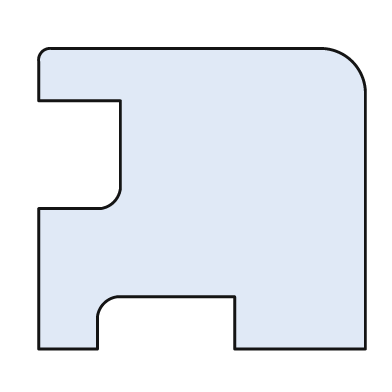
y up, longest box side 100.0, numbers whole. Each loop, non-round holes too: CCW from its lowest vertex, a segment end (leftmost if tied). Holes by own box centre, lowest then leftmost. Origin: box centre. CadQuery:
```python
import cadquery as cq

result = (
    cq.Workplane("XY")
    .moveTo(-50.0, -46.0)
    .lineTo(-32.0, -46.0)
    .lineTo(-32.0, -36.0)
    .threePointArc((-30.0, -32.0), (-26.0, -30.0))
    .lineTo(10.0, -30.0)
    .lineTo(10.0, -46.0)
    .lineTo(50.0, -46.0)
    .lineTo(50.0, 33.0)
    .threePointArc((46.0, 42.0), (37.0, 46.0))
    .lineTo(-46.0, 46.0)
    .threePointArc((-49.0, 45.0), (-50.0, 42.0))
    .lineTo(-50.0, 30.0)
    .lineTo(-25.0, 30.0)
    .lineTo(-25.0, 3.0)
    .threePointArc((-27.0, -1.0), (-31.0, -3.0))
    .lineTo(-50.0, -3.0)
    .close()
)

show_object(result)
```